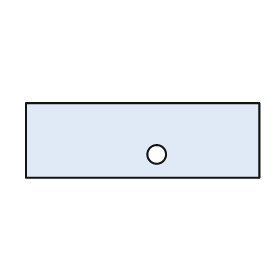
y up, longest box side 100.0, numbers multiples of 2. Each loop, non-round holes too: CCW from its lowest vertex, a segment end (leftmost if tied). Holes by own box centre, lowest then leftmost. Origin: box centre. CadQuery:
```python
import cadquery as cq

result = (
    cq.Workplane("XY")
    .moveTo(-50.0, -16.0)
    .lineTo(50.0, -16.0)
    .lineTo(50.0, 16.0)
    .lineTo(-50.0, 16.0)
    .close()
    .moveTo(6.0, -6.0)
    .circle(4.0)
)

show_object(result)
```